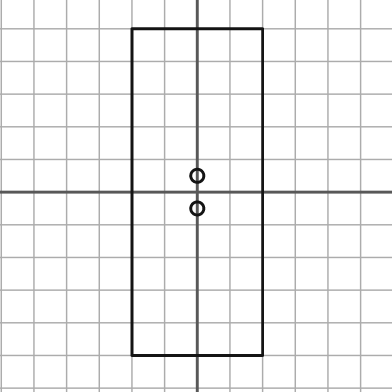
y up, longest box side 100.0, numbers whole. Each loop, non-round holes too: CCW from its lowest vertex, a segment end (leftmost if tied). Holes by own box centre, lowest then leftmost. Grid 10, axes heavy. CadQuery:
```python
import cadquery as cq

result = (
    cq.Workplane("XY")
    .moveTo(-20.0, -50.0)
    .lineTo(20.0, -50.0)
    .lineTo(20.0, 50.0)
    .lineTo(-20.0, 50.0)
    .close()
    .moveTo(0.0, -5.0)
    .circle(2.0)
    .moveTo(0.0, 5.0)
    .circle(2.0)
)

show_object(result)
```